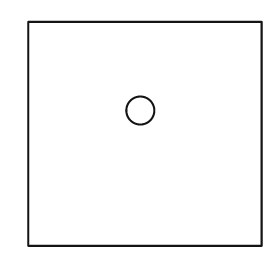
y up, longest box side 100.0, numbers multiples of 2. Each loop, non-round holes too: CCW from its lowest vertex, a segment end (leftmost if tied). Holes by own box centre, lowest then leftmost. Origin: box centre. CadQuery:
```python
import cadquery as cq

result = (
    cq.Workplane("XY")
    .moveTo(-50.0, -48.0)
    .lineTo(50.0, -48.0)
    .lineTo(50.0, 48.0)
    .lineTo(-50.0, 48.0)
    .close()
    .moveTo(-2.0, 10.0)
    .circle(6.0)
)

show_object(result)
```